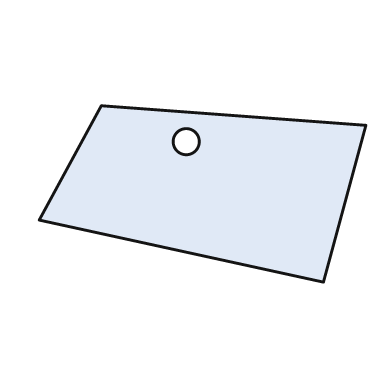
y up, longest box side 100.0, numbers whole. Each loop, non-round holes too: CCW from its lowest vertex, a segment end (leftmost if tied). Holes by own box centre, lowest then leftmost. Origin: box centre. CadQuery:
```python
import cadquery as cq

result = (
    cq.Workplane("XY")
    .moveTo(37.0, -27.0)
    .lineTo(50.0, 21.0)
    .lineTo(-31.0, 27.0)
    .lineTo(-50.0, -8.0)
    .close()
    .moveTo(-5.0, 16.0)
    .circle(4.0)
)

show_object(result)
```